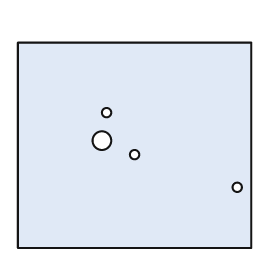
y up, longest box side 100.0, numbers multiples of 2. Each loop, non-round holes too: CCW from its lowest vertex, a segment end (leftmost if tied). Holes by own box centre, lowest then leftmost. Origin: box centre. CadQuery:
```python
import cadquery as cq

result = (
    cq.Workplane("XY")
    .moveTo(-50.0, -44.0)
    .lineTo(50.0, -44.0)
    .lineTo(50.0, 44.0)
    .lineTo(-50.0, 44.0)
    .close()
    .moveTo(44.0, -18.0)
    .circle(2.0)
    .moveTo(0.0, -4.0)
    .circle(2.0)
    .moveTo(-14.0, 2.0)
    .circle(4.0)
    .moveTo(-12.0, 14.0)
    .circle(2.0)
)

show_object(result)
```